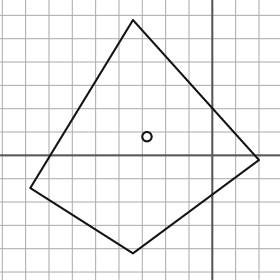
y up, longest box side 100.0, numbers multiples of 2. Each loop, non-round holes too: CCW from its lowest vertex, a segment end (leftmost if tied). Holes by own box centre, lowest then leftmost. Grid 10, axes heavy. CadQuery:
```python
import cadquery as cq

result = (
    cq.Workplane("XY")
    .moveTo(-34.0, -42.0)
    .lineTo(20.0, -2.0)
    .lineTo(-34.0, 58.0)
    .lineTo(-78.0, -14.0)
    .close()
    .moveTo(-28.0, 8.0)
    .circle(2.0)
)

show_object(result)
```